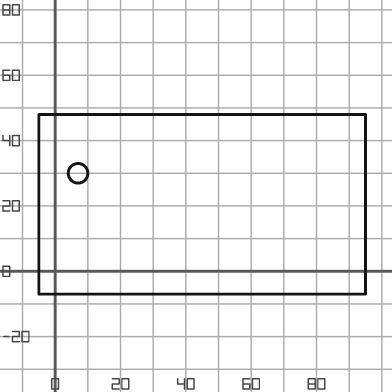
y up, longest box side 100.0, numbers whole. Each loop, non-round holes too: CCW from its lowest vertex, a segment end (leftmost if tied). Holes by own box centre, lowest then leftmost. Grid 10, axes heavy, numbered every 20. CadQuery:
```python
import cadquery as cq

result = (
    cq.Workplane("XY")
    .moveTo(-5.0, -7.0)
    .lineTo(95.0, -7.0)
    .lineTo(95.0, 48.0)
    .lineTo(-5.0, 48.0)
    .close()
    .moveTo(7.0, 30.0)
    .circle(3.0)
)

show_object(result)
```